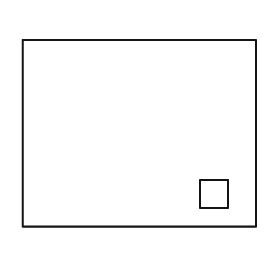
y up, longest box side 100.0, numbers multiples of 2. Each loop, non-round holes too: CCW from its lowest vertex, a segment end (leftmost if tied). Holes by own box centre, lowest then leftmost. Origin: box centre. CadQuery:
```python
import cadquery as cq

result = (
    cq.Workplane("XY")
    .moveTo(-50.0, -40.0)
    .lineTo(50.0, -40.0)
    .lineTo(50.0, 40.0)
    .lineTo(-50.0, 40.0)
    .close()
    .moveTo(26.0, -32.0)
    .lineTo(38.0, -32.0)
    .lineTo(38.0, -20.0)
    .lineTo(26.0, -20.0)
    .close()
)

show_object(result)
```